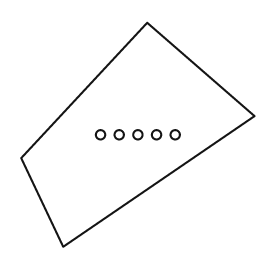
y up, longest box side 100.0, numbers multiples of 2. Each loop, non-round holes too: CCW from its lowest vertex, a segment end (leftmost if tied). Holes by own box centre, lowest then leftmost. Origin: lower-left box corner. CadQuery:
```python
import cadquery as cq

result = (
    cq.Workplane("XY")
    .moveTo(18.0, 0.0)
    .lineTo(100.0, 56.0)
    .lineTo(54.0, 96.0)
    .lineTo(0.0, 38.0)
    .close()
    .moveTo(34.0, 48.0)
    .circle(2.0)
    .moveTo(42.0, 48.0)
    .circle(2.0)
    .moveTo(50.0, 48.0)
    .circle(2.0)
    .moveTo(58.0, 48.0)
    .circle(2.0)
    .moveTo(66.0, 48.0)
    .circle(2.0)
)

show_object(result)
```